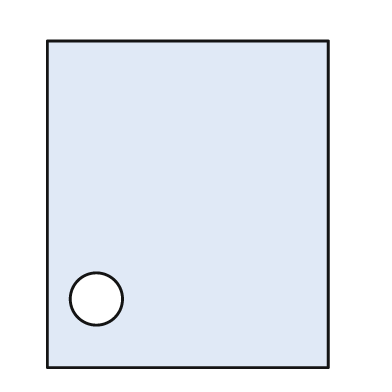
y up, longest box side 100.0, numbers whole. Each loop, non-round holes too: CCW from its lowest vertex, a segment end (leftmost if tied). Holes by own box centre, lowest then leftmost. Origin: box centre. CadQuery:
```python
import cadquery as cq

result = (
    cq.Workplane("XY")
    .moveTo(-43.0, -50.0)
    .lineTo(43.0, -50.0)
    .lineTo(43.0, 50.0)
    .lineTo(-43.0, 50.0)
    .close()
    .moveTo(-28.0, -29.0)
    .circle(8.0)
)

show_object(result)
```